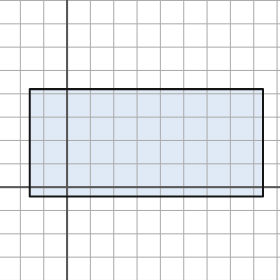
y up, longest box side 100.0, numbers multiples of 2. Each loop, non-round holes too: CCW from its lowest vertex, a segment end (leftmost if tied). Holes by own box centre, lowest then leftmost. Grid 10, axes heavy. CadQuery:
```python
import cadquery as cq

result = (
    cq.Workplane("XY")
    .moveTo(-16.0, -4.0)
    .lineTo(84.0, -4.0)
    .lineTo(84.0, 42.0)
    .lineTo(-16.0, 42.0)
    .close()
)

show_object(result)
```